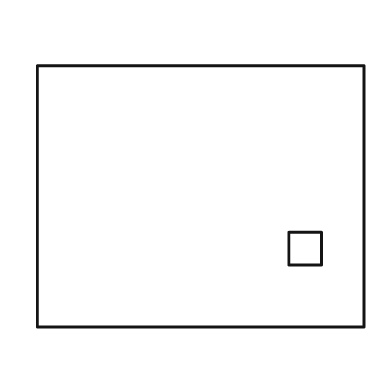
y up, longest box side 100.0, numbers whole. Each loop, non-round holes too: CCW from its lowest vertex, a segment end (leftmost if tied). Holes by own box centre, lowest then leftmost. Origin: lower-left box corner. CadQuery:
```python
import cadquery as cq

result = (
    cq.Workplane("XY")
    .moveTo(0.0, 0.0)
    .lineTo(100.0, 0.0)
    .lineTo(100.0, 80.0)
    .lineTo(0.0, 80.0)
    .close()
    .moveTo(77.0, 19.0)
    .lineTo(87.0, 19.0)
    .lineTo(87.0, 29.0)
    .lineTo(77.0, 29.0)
    .close()
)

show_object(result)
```